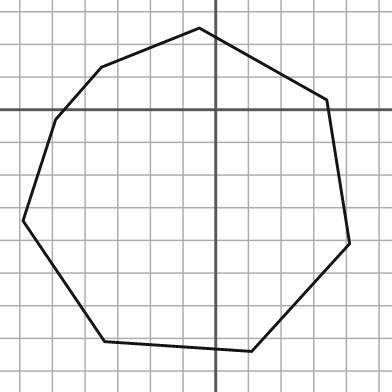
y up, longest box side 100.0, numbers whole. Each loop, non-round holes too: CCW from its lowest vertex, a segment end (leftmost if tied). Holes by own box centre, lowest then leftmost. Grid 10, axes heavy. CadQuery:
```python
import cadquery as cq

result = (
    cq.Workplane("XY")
    .moveTo(11.0, -74.0)
    .lineTo(41.0, -41.0)
    .lineTo(34.0, 3.0)
    .lineTo(-5.0, 25.0)
    .lineTo(-35.0, 13.0)
    .lineTo(-49.0, -3.0)
    .lineTo(-59.0, -34.0)
    .lineTo(-34.0, -71.0)
    .close()
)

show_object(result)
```